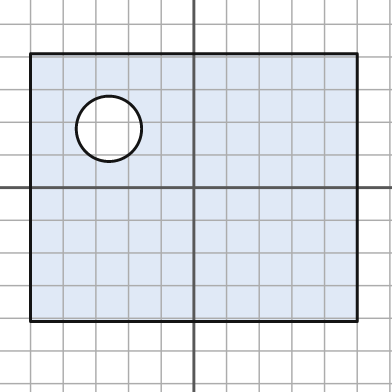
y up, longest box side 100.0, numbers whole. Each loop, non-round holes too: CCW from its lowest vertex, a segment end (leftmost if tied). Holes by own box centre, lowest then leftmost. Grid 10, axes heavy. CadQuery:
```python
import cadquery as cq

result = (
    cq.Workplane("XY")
    .moveTo(-50.0, -41.0)
    .lineTo(50.0, -41.0)
    .lineTo(50.0, 41.0)
    .lineTo(-50.0, 41.0)
    .close()
    .moveTo(-26.0, 18.0)
    .circle(10.0)
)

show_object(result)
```